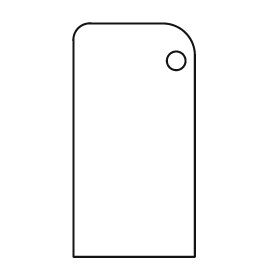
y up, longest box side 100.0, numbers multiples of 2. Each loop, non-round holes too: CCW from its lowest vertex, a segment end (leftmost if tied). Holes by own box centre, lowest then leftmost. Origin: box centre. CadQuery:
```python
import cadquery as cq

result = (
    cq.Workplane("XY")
    .moveTo(-26.0, -50.0)
    .lineTo(26.0, -50.0)
    .lineTo(26.0, 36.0)
    .threePointArc((22.0, 46.0), (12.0, 50.0))
    .lineTo(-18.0, 50.0)
    .threePointArc((-24.0, 48.0), (-26.0, 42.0))
    .close()
    .moveTo(18.0, 34.0)
    .circle(4.0)
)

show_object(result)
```